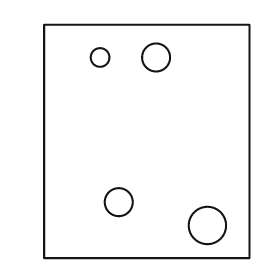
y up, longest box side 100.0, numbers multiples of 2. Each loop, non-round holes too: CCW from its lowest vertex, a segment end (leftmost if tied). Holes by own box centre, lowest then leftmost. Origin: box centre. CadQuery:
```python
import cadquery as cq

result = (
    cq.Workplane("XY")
    .moveTo(-44.0, -50.0)
    .lineTo(44.0, -50.0)
    .lineTo(44.0, 50.0)
    .lineTo(-44.0, 50.0)
    .close()
    .moveTo(26.0, -36.0)
    .circle(8.0)
    .moveTo(-12.0, -26.0)
    .circle(6.0)
    .moveTo(-20.0, 36.0)
    .circle(4.0)
    .moveTo(4.0, 36.0)
    .circle(6.0)
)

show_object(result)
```